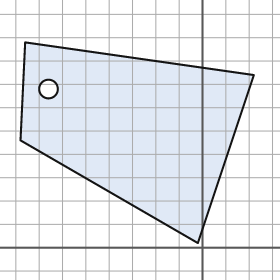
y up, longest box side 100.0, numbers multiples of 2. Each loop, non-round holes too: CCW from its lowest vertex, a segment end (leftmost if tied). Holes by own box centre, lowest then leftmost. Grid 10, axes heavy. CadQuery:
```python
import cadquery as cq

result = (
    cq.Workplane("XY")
    .moveTo(-2.0, 2.0)
    .lineTo(22.0, 74.0)
    .lineTo(-76.0, 88.0)
    .lineTo(-78.0, 46.0)
    .close()
    .moveTo(-66.0, 68.0)
    .circle(4.0)
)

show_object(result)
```